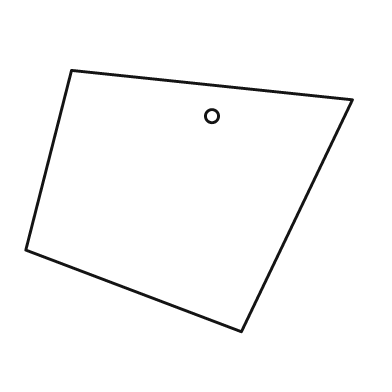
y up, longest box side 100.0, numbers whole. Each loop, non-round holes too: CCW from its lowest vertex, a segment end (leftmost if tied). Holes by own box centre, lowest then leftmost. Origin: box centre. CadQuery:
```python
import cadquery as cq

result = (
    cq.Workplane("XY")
    .moveTo(16.0, -40.0)
    .lineTo(50.0, 31.0)
    .lineTo(-36.0, 40.0)
    .lineTo(-50.0, -15.0)
    .close()
    .moveTo(7.0, 26.0)
    .circle(2.0)
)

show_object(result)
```